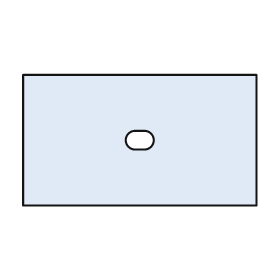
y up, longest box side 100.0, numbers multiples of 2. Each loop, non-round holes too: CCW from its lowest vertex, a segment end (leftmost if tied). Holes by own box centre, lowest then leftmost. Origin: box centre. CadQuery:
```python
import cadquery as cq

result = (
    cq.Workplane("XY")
    .moveTo(-50.0, -28.0)
    .lineTo(50.0, -28.0)
    .lineTo(50.0, 28.0)
    .lineTo(-50.0, 28.0)
    .close()
    .moveTo(-2.0, -4.0)
    .lineTo(2.0, -4.0)
    .threePointArc((6.0, 0.0), (2.0, 4.0))
    .lineTo(-2.0, 4.0)
    .threePointArc((-6.0, 0.0), (-2.0, -4.0))
    .close()
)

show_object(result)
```